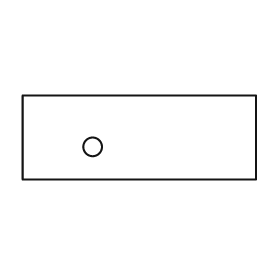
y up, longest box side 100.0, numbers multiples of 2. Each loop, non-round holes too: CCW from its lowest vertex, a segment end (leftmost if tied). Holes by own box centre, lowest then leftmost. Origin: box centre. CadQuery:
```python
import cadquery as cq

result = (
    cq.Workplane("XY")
    .moveTo(-50.0, -18.0)
    .lineTo(50.0, -18.0)
    .lineTo(50.0, 18.0)
    .lineTo(-50.0, 18.0)
    .close()
    .moveTo(-20.0, -4.0)
    .circle(4.0)
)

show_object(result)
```